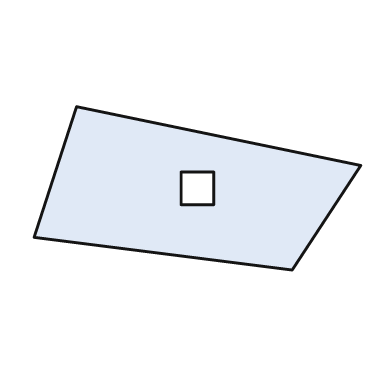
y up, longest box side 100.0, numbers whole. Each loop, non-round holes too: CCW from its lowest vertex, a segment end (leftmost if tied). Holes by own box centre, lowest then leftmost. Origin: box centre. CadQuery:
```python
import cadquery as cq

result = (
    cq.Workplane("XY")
    .moveTo(29.0, -25.0)
    .lineTo(50.0, 7.0)
    .lineTo(-37.0, 25.0)
    .lineTo(-50.0, -15.0)
    .close()
    .moveTo(-5.0, -5.0)
    .lineTo(5.0, -5.0)
    .lineTo(5.0, 5.0)
    .lineTo(-5.0, 5.0)
    .close()
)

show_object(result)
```